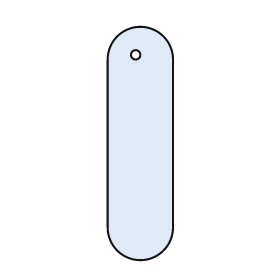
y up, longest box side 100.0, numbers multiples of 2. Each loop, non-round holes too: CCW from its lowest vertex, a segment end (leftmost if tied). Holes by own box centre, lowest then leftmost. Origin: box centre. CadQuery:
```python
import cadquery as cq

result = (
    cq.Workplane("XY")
    .moveTo(-14.0, -36.0)
    .threePointArc((0.0, -50.0), (14.0, -36.0))
    .lineTo(14.0, 36.0)
    .threePointArc((0.0, 50.0), (-14.0, 36.0))
    .close()
    .moveTo(-2.0, 38.0)
    .circle(2.0)
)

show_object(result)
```